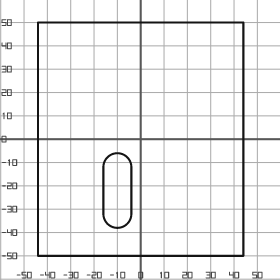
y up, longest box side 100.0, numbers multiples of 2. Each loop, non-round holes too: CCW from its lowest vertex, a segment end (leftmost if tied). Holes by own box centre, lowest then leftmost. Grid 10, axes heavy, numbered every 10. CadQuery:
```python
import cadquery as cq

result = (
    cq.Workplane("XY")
    .moveTo(-44.0, -50.0)
    .lineTo(44.0, -50.0)
    .lineTo(44.0, 50.0)
    .lineTo(-44.0, 50.0)
    .close()
    .moveTo(-16.0, -32.0)
    .threePointArc((-10.0, -38.0), (-4.0, -32.0))
    .lineTo(-4.0, -12.0)
    .threePointArc((-10.0, -6.0), (-16.0, -12.0))
    .close()
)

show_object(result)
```